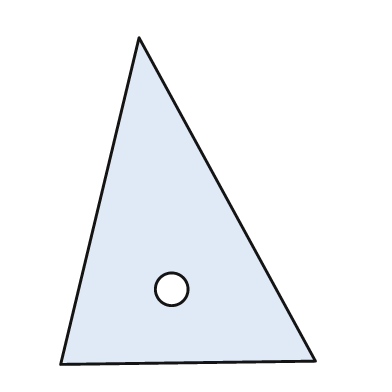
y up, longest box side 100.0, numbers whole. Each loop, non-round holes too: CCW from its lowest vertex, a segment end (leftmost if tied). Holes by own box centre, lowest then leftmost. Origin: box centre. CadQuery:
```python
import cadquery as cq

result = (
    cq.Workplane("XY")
    .moveTo(-39.0, -50.0)
    .lineTo(39.0, -49.0)
    .lineTo(-15.0, 50.0)
    .close()
    .moveTo(-5.0, -27.0)
    .circle(5.0)
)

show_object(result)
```